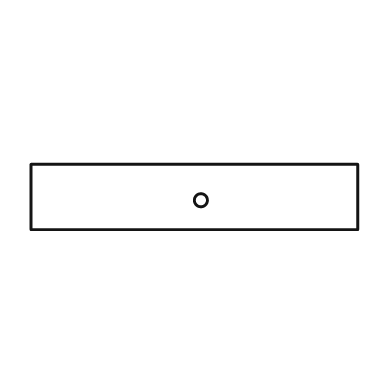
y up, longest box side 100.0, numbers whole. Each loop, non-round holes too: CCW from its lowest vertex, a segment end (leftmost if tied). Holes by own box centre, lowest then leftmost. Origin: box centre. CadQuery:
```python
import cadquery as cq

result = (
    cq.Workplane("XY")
    .moveTo(-50.0, -10.0)
    .lineTo(50.0, -10.0)
    .lineTo(50.0, 10.0)
    .lineTo(-50.0, 10.0)
    .close()
    .moveTo(2.0, -1.0)
    .circle(2.0)
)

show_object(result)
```